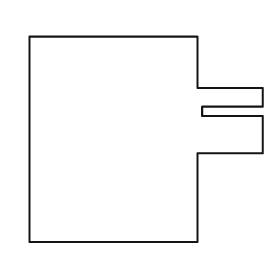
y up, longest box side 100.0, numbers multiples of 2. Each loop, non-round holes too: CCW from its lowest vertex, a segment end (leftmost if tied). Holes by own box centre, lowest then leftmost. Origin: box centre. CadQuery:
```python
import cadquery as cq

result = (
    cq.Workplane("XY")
    .moveTo(-50.0, -44.0)
    .lineTo(22.0, -44.0)
    .lineTo(22.0, -6.0)
    .lineTo(50.0, -6.0)
    .lineTo(50.0, 10.0)
    .lineTo(24.0, 10.0)
    .lineTo(24.0, 14.0)
    .lineTo(50.0, 14.0)
    .lineTo(50.0, 22.0)
    .lineTo(22.0, 22.0)
    .lineTo(22.0, 44.0)
    .lineTo(-50.0, 44.0)
    .close()
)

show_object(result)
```